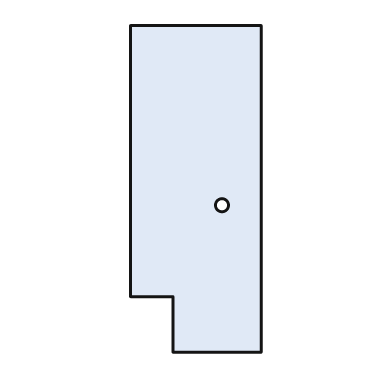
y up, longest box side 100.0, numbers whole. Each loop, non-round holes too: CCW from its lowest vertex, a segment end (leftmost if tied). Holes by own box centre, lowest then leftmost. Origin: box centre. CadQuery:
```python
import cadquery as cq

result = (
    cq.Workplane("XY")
    .moveTo(-7.0, -50.0)
    .lineTo(20.0, -50.0)
    .lineTo(20.0, 50.0)
    .lineTo(-20.0, 50.0)
    .lineTo(-20.0, -33.0)
    .lineTo(-7.0, -33.0)
    .close()
    .moveTo(8.0, -5.0)
    .circle(2.0)
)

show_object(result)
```